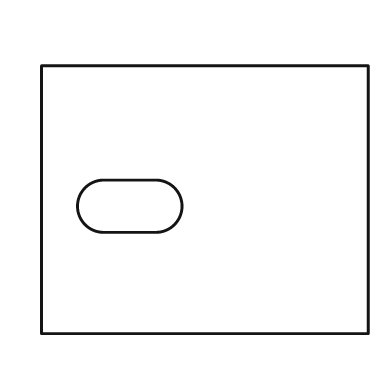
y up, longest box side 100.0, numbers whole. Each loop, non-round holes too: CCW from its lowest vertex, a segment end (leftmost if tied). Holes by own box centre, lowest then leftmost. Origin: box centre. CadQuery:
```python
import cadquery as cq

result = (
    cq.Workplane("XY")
    .moveTo(-50.0, -41.0)
    .lineTo(50.0, -41.0)
    .lineTo(50.0, 41.0)
    .lineTo(-50.0, 41.0)
    .close()
    .moveTo(-31.0, -10.0)
    .lineTo(-15.0, -10.0)
    .threePointArc((-7.0, -2.0), (-15.0, 6.0))
    .lineTo(-31.0, 6.0)
    .threePointArc((-39.0, -2.0), (-31.0, -10.0))
    .close()
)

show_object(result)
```